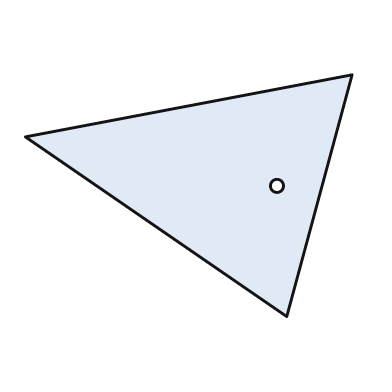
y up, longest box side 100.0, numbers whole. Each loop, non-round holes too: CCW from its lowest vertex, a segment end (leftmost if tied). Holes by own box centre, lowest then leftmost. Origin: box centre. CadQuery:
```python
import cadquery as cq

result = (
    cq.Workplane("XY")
    .moveTo(30.0, -37.0)
    .lineTo(50.0, 37.0)
    .lineTo(-50.0, 18.0)
    .close()
    .moveTo(27.0, 3.0)
    .circle(2.0)
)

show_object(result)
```